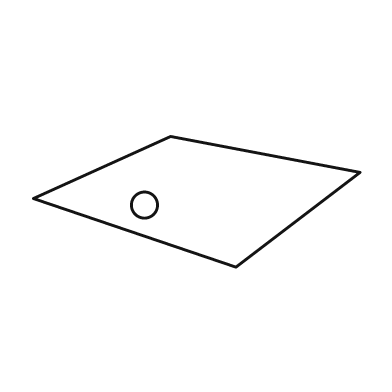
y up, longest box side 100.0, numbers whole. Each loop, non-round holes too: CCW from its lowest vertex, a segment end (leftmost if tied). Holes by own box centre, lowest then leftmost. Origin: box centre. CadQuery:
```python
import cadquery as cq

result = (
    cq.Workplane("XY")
    .moveTo(12.0, -20.0)
    .lineTo(50.0, 9.0)
    .lineTo(-8.0, 20.0)
    .lineTo(-50.0, 1.0)
    .close()
    .moveTo(-16.0, -1.0)
    .circle(4.0)
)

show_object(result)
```